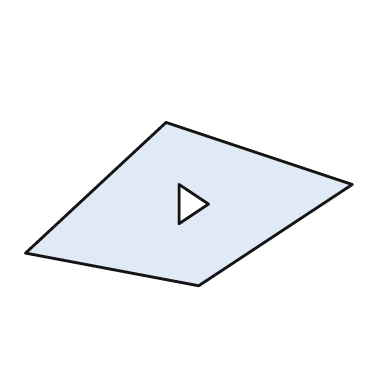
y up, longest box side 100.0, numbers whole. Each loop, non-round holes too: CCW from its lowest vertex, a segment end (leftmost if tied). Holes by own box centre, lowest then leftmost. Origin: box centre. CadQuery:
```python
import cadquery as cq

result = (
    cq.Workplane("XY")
    .moveTo(3.0, -25.0)
    .lineTo(50.0, 6.0)
    .lineTo(-7.0, 25.0)
    .lineTo(-50.0, -15.0)
    .close()
    .moveTo(-3.0, -6.0)
    .lineTo(6.0, 0.0)
    .lineTo(-3.0, 6.0)
    .close()
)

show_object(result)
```